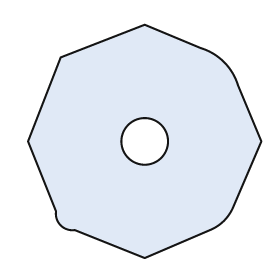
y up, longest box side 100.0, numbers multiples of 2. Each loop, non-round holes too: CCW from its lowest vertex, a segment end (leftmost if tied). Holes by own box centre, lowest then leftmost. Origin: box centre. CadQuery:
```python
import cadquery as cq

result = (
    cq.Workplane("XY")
    .moveTo(0.0, -50.0)
    .lineTo(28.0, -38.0)
    .threePointArc((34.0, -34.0), (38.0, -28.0))
    .lineTo(50.0, 0.0)
    .lineTo(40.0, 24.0)
    .threePointArc((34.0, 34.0), (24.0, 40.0))
    .lineTo(0.0, 50.0)
    .lineTo(-36.0, 36.0)
    .lineTo(-50.0, 0.0)
    .lineTo(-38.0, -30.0)
    .threePointArc((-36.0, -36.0), (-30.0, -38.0))
    .close()
    .moveTo(0.0, 0.0)
    .circle(10.0)
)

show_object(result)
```